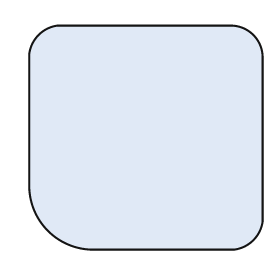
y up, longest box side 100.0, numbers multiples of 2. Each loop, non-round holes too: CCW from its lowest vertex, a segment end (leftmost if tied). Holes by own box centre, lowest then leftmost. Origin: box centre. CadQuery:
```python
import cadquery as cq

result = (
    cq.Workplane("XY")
    .moveTo(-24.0, -48.0)
    .lineTo(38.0, -48.0)
    .threePointArc((46.0, -44.0), (50.0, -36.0))
    .lineTo(50.0, 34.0)
    .threePointArc((46.0, 44.0), (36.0, 48.0))
    .lineTo(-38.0, 48.0)
    .threePointArc((-46.0, 44.0), (-50.0, 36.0))
    .lineTo(-50.0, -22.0)
    .threePointArc((-42.0, -40.0), (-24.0, -48.0))
    .close()
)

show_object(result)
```